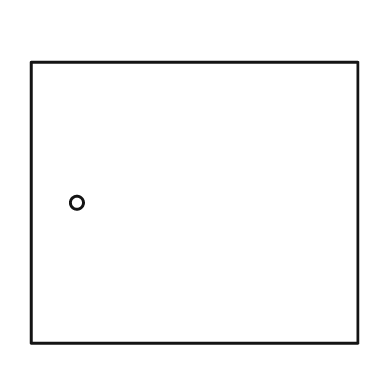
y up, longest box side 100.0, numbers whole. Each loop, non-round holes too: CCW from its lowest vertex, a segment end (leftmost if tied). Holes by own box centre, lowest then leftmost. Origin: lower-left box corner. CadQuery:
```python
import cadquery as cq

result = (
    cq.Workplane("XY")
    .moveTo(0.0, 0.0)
    .lineTo(100.0, 0.0)
    .lineTo(100.0, 86.0)
    .lineTo(0.0, 86.0)
    .close()
    .moveTo(14.0, 43.0)
    .circle(2.0)
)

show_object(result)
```